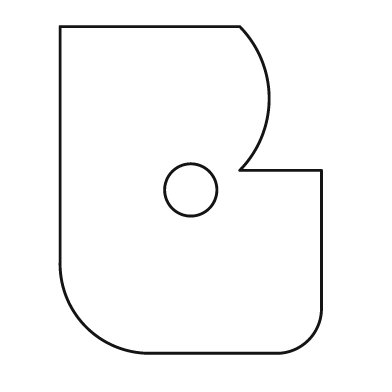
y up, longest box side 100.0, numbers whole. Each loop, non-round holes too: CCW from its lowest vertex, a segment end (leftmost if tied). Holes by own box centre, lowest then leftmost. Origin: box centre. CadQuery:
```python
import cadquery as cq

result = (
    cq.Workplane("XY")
    .moveTo(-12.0, -50.0)
    .lineTo(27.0, -50.0)
    .threePointArc((36.0, -46.0), (40.0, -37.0))
    .lineTo(40.0, 6.0)
    .lineTo(15.0, 6.0)
    .threePointArc((24.0, 28.0), (15.0, 50.0))
    .lineTo(-40.0, 50.0)
    .lineTo(-40.0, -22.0)
    .threePointArc((-32.0, -42.0), (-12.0, -50.0))
    .close()
    .moveTo(0.0, 0.0)
    .circle(8.0)
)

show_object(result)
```